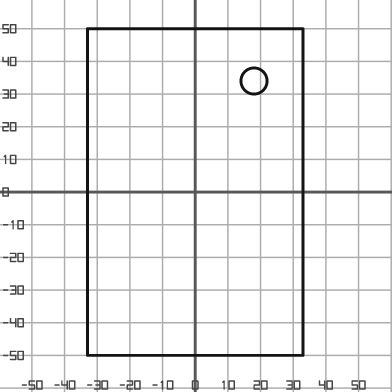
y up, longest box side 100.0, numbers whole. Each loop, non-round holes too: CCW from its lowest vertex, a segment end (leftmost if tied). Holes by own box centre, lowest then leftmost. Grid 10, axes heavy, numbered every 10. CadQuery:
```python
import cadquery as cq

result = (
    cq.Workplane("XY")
    .moveTo(-33.0, -50.0)
    .lineTo(33.0, -50.0)
    .lineTo(33.0, 50.0)
    .lineTo(-33.0, 50.0)
    .close()
    .moveTo(18.0, 34.0)
    .circle(4.0)
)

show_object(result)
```